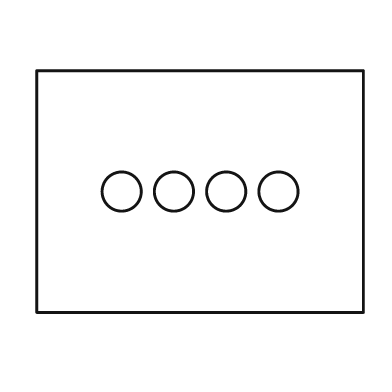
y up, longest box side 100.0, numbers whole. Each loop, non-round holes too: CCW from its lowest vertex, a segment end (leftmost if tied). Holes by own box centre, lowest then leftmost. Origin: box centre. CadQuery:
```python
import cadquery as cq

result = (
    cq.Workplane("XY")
    .moveTo(-50.0, -37.0)
    .lineTo(50.0, -37.0)
    .lineTo(50.0, 37.0)
    .lineTo(-50.0, 37.0)
    .close()
    .moveTo(-24.0, 0.0)
    .circle(6.0)
    .moveTo(-8.0, 0.0)
    .circle(6.0)
    .moveTo(8.0, 0.0)
    .circle(6.0)
    .moveTo(24.0, 0.0)
    .circle(6.0)
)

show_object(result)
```